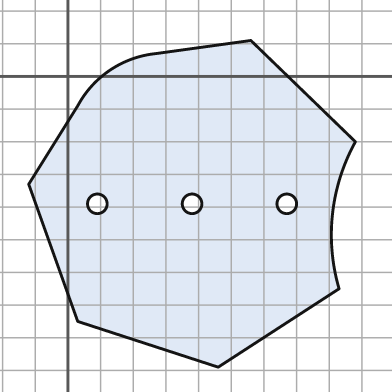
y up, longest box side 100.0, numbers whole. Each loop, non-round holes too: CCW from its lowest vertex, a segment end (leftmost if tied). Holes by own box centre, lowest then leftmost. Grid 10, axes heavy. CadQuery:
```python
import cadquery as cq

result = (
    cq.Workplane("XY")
    .moveTo(46.0, -89.0)
    .lineTo(83.0, -65.0)
    .threePointArc((81.0, -42.0), (88.0, -20.0))
    .lineTo(56.0, 11.0)
    .lineTo(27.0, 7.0)
    .threePointArc((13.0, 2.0), (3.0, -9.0))
    .lineTo(-12.0, -33.0)
    .lineTo(3.0, -75.0)
    .close()
    .moveTo(9.0, -39.0)
    .circle(3.0)
    .moveTo(38.0, -39.0)
    .circle(3.0)
    .moveTo(67.0, -39.0)
    .circle(3.0)
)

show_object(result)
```